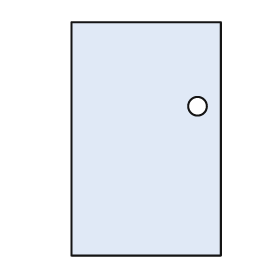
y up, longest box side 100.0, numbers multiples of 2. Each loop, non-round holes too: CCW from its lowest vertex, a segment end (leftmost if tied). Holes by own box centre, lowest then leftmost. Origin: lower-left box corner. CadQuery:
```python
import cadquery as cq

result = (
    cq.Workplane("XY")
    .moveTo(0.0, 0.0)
    .lineTo(64.0, 0.0)
    .lineTo(64.0, 100.0)
    .lineTo(0.0, 100.0)
    .close()
    .moveTo(54.0, 64.0)
    .circle(4.0)
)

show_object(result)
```